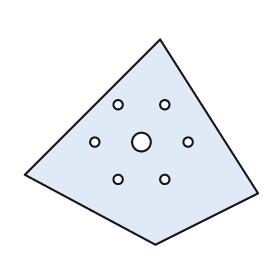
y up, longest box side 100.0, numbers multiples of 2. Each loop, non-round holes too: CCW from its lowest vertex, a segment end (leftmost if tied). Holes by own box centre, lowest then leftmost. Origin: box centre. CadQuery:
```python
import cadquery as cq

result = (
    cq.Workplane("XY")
    .moveTo(6.0, -44.0)
    .lineTo(50.0, -22.0)
    .lineTo(8.0, 44.0)
    .lineTo(-50.0, -14.0)
    .close()
    .moveTo(-10.0, -16.0)
    .circle(2.0)
    .moveTo(10.0, -16.0)
    .circle(2.0)
    .moveTo(-20.0, 0.0)
    .circle(2.0)
    .moveTo(0.0, 0.0)
    .circle(4.0)
    .moveTo(20.0, 0.0)
    .circle(2.0)
    .moveTo(-10.0, 16.0)
    .circle(2.0)
    .moveTo(10.0, 16.0)
    .circle(2.0)
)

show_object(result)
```